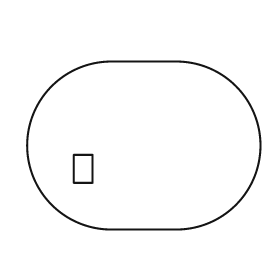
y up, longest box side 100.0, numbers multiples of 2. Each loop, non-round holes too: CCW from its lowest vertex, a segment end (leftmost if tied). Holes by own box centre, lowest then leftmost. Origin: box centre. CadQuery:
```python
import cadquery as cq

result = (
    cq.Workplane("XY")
    .moveTo(-14.0, -36.0)
    .lineTo(14.0, -36.0)
    .threePointArc((50.0, 0.0), (14.0, 36.0))
    .lineTo(-14.0, 36.0)
    .threePointArc((-50.0, 0.0), (-14.0, -36.0))
    .close()
    .moveTo(-30.0, -16.0)
    .lineTo(-22.0, -16.0)
    .lineTo(-22.0, -4.0)
    .lineTo(-30.0, -4.0)
    .close()
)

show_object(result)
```